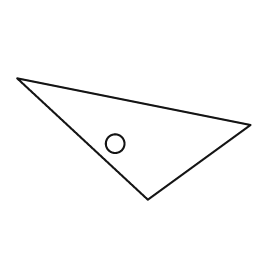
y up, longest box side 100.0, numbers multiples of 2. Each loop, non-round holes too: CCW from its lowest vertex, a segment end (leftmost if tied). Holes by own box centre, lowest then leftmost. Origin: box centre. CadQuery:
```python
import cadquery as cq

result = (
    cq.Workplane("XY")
    .moveTo(6.0, -26.0)
    .lineTo(50.0, 6.0)
    .lineTo(-50.0, 26.0)
    .close()
    .moveTo(-8.0, -2.0)
    .circle(4.0)
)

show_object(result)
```